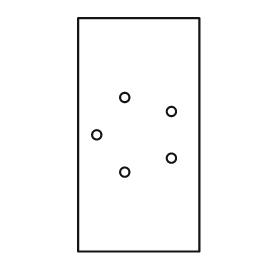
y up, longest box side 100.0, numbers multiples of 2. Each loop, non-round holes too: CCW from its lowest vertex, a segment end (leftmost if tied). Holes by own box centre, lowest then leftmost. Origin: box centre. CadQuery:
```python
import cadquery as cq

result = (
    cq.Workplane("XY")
    .moveTo(-26.0, -50.0)
    .lineTo(26.0, -50.0)
    .lineTo(26.0, 50.0)
    .lineTo(-26.0, 50.0)
    .close()
    .moveTo(-6.0, -16.0)
    .circle(2.0)
    .moveTo(14.0, -10.0)
    .circle(2.0)
    .moveTo(-18.0, 0.0)
    .circle(2.0)
    .moveTo(14.0, 10.0)
    .circle(2.0)
    .moveTo(-6.0, 16.0)
    .circle(2.0)
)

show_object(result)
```